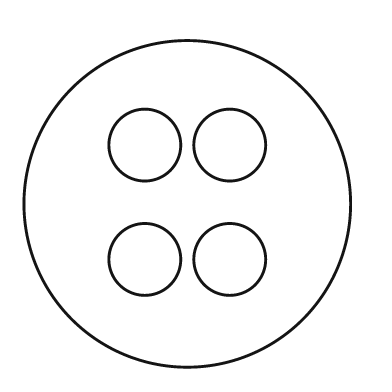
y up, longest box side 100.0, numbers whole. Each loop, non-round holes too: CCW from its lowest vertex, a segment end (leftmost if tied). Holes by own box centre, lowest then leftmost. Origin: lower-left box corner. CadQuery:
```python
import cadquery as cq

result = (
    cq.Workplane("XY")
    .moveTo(50.0, 50.0)
    .circle(50.0)
    .moveTo(37.0, 33.0)
    .circle(11.0)
    .moveTo(63.0, 33.0)
    .circle(11.0)
    .moveTo(37.0, 68.0)
    .circle(11.0)
    .moveTo(63.0, 68.0)
    .circle(11.0)
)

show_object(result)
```